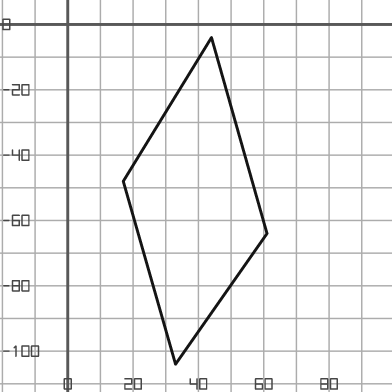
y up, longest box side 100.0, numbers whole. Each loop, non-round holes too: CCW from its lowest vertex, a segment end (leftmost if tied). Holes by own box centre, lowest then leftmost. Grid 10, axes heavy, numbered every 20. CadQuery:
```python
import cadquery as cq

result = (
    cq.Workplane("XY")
    .moveTo(33.0, -104.0)
    .lineTo(61.0, -64.0)
    .lineTo(44.0, -4.0)
    .lineTo(17.0, -48.0)
    .close()
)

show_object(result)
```